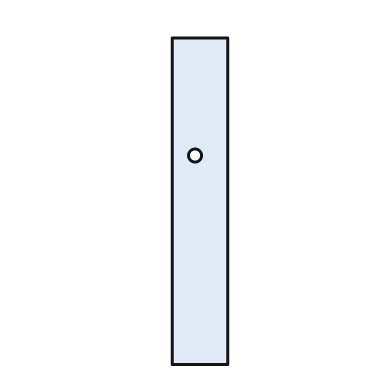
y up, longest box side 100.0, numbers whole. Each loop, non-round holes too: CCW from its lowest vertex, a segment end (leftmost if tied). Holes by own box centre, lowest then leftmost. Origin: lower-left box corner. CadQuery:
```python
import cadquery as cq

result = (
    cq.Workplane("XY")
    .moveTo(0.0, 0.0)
    .lineTo(17.0, 0.0)
    .lineTo(17.0, 100.0)
    .lineTo(0.0, 100.0)
    .close()
    .moveTo(7.0, 64.0)
    .circle(2.0)
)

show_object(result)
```